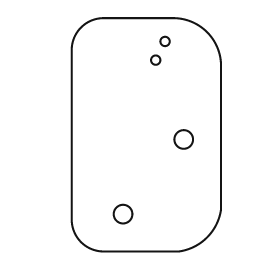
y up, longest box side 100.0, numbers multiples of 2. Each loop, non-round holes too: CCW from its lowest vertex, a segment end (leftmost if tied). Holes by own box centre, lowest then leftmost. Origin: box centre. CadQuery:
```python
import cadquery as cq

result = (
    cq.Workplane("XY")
    .moveTo(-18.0, -50.0)
    .lineTo(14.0, -50.0)
    .threePointArc((26.0, -44.0), (32.0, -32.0))
    .lineTo(32.0, 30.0)
    .threePointArc((26.0, 44.0), (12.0, 50.0))
    .lineTo(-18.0, 50.0)
    .threePointArc((-28.0, 46.0), (-32.0, 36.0))
    .lineTo(-32.0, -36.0)
    .threePointArc((-28.0, -46.0), (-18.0, -50.0))
    .close()
    .moveTo(-10.0, -34.0)
    .circle(4.0)
    .moveTo(16.0, -2.0)
    .circle(4.0)
    .moveTo(4.0, 32.0)
    .circle(2.0)
    .moveTo(8.0, 40.0)
    .circle(2.0)
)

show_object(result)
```